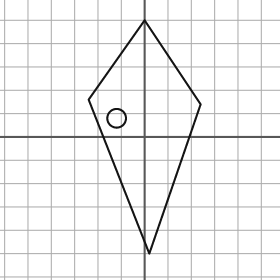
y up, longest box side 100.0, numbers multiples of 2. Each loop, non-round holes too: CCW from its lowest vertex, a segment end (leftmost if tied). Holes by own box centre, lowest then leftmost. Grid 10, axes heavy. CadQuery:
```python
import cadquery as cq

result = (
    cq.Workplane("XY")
    .moveTo(2.0, -50.0)
    .lineTo(24.0, 14.0)
    .lineTo(0.0, 50.0)
    .lineTo(-24.0, 16.0)
    .close()
    .moveTo(-12.0, 8.0)
    .circle(4.0)
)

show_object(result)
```